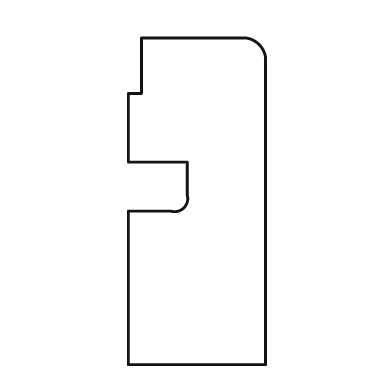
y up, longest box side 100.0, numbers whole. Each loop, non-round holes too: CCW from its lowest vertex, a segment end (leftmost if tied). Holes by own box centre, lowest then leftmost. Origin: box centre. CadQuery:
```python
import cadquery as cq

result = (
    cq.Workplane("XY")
    .moveTo(-21.0, -50.0)
    .lineTo(21.0, -50.0)
    .lineTo(21.0, 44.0)
    .threePointArc((19.0, 48.0), (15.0, 50.0))
    .lineTo(-17.0, 50.0)
    .lineTo(-17.0, 33.0)
    .lineTo(-21.0, 33.0)
    .lineTo(-21.0, 12.0)
    .lineTo(-3.0, 12.0)
    .lineTo(-3.0, 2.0)
    .threePointArc((-4.0, -2.0), (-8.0, -3.0))
    .lineTo(-21.0, -3.0)
    .close()
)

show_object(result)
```